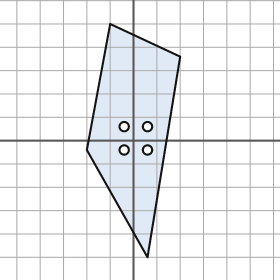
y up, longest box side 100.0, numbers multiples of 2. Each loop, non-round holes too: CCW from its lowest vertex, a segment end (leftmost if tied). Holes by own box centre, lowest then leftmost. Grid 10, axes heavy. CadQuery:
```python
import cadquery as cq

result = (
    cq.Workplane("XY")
    .moveTo(6.0, -50.0)
    .lineTo(20.0, 36.0)
    .lineTo(-10.0, 50.0)
    .lineTo(-20.0, -4.0)
    .close()
    .moveTo(-4.0, -4.0)
    .circle(2.0)
    .moveTo(6.0, -4.0)
    .circle(2.0)
    .moveTo(-4.0, 6.0)
    .circle(2.0)
    .moveTo(6.0, 6.0)
    .circle(2.0)
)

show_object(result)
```